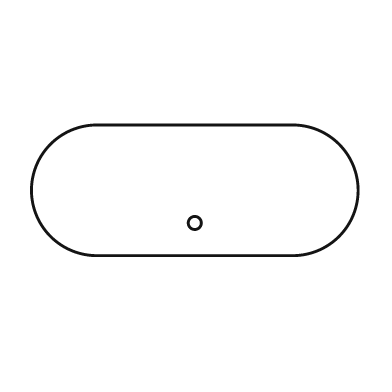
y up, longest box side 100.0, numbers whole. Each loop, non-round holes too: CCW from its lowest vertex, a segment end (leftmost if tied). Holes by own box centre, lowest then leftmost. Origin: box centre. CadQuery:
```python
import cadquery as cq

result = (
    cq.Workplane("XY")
    .moveTo(-30.0, -20.0)
    .lineTo(30.0, -20.0)
    .threePointArc((50.0, 0.0), (30.0, 20.0))
    .lineTo(-30.0, 20.0)
    .threePointArc((-50.0, 0.0), (-30.0, -20.0))
    .close()
    .moveTo(0.0, -10.0)
    .circle(2.0)
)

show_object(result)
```